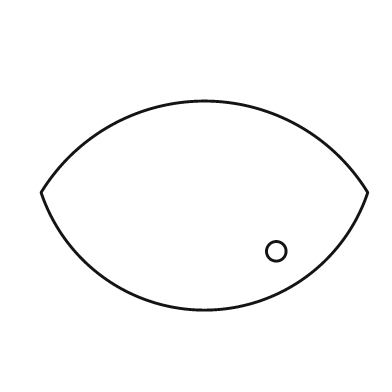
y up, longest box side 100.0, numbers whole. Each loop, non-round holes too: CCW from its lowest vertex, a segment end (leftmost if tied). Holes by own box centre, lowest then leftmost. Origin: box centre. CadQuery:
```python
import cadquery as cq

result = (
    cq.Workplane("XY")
    .moveTo(-50.0, 4.0)
    .threePointArc((0.0, -32.0), (50.0, 4.0))
    .threePointArc((0.0, 32.0), (-50.0, 4.0))
    .close()
    .moveTo(22.0, -14.0)
    .circle(3.0)
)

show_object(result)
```